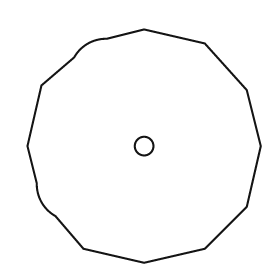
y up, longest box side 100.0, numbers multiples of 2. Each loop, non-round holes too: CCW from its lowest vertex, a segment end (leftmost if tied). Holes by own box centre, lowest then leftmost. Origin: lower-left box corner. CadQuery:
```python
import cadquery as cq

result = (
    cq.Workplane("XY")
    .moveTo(50.0, 0.0)
    .lineTo(76.0, 6.0)
    .lineTo(94.0, 24.0)
    .lineTo(100.0, 50.0)
    .lineTo(94.0, 74.0)
    .lineTo(76.0, 94.0)
    .lineTo(50.0, 100.0)
    .lineTo(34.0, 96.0)
    .threePointArc((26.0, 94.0), (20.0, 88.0))
    .lineTo(6.0, 76.0)
    .lineTo(0.0, 50.0)
    .lineTo(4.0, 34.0)
    .threePointArc((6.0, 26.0), (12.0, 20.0))
    .lineTo(24.0, 6.0)
    .close()
    .moveTo(50.0, 50.0)
    .circle(4.0)
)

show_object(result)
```